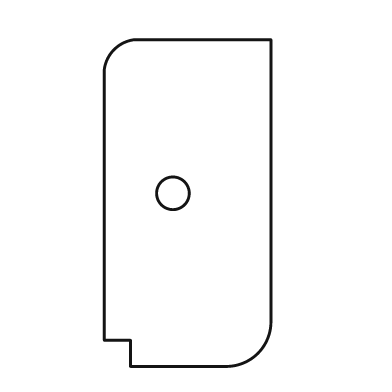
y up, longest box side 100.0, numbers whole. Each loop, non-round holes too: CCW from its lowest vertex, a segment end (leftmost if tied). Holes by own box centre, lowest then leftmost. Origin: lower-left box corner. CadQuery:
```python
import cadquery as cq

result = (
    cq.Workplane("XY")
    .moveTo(8.0, 0.0)
    .lineTo(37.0, 0.0)
    .threePointArc((47.0, 4.0), (51.0, 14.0))
    .lineTo(51.0, 100.0)
    .lineTo(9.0, 100.0)
    .threePointArc((3.0, 97.0), (0.0, 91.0))
    .lineTo(0.0, 8.0)
    .lineTo(8.0, 8.0)
    .close()
    .moveTo(21.0, 53.0)
    .circle(5.0)
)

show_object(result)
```